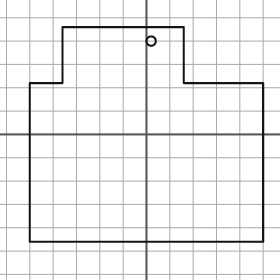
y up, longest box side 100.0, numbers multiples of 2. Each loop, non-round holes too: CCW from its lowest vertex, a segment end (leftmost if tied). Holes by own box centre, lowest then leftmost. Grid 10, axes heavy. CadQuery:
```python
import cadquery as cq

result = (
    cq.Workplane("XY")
    .moveTo(-50.0, -46.0)
    .lineTo(50.0, -46.0)
    .lineTo(50.0, 22.0)
    .lineTo(16.0, 22.0)
    .lineTo(16.0, 46.0)
    .lineTo(-36.0, 46.0)
    .lineTo(-36.0, 22.0)
    .lineTo(-50.0, 22.0)
    .close()
    .moveTo(2.0, 40.0)
    .circle(2.0)
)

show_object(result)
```